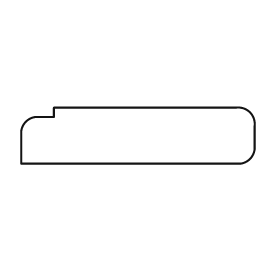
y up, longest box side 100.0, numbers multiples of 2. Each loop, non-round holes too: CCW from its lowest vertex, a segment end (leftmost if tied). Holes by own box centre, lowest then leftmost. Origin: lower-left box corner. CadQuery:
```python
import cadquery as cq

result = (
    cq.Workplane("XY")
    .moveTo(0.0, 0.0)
    .lineTo(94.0, 0.0)
    .threePointArc((98.0, 2.0), (100.0, 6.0))
    .lineTo(100.0, 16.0)
    .threePointArc((98.0, 22.0), (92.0, 24.0))
    .lineTo(14.0, 24.0)
    .lineTo(14.0, 20.0)
    .lineTo(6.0, 20.0)
    .threePointArc((2.0, 18.0), (0.0, 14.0))
    .close()
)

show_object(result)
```